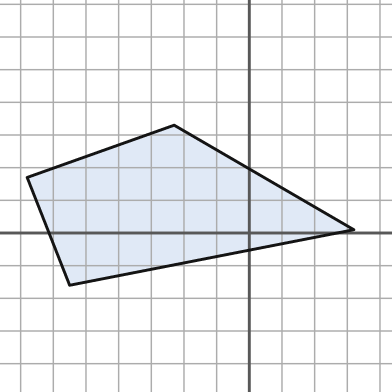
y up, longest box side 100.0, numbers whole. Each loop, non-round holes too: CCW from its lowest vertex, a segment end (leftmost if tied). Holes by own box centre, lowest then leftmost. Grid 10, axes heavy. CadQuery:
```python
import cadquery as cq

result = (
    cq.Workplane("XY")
    .moveTo(-55.0, -16.0)
    .lineTo(32.0, 1.0)
    .lineTo(-23.0, 33.0)
    .lineTo(-68.0, 17.0)
    .close()
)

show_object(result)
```